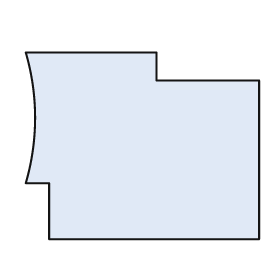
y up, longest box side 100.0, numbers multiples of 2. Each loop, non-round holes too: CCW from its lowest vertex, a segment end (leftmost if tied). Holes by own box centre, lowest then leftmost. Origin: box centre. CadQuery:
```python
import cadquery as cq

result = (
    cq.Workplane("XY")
    .moveTo(-40.0, -40.0)
    .lineTo(50.0, -40.0)
    .lineTo(50.0, 28.0)
    .lineTo(6.0, 28.0)
    .lineTo(6.0, 40.0)
    .lineTo(-50.0, 40.0)
    .threePointArc((-46.0, 12.0), (-50.0, -16.0))
    .lineTo(-40.0, -16.0)
    .close()
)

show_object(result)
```